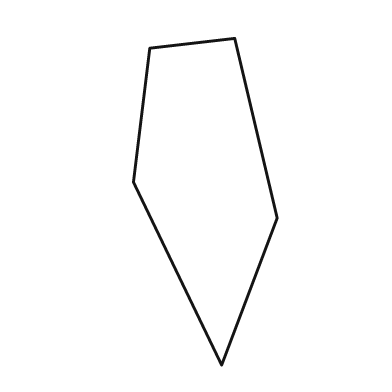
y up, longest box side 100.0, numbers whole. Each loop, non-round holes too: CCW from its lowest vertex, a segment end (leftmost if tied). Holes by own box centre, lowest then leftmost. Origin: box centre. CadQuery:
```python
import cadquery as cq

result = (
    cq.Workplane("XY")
    .moveTo(5.0, -50.0)
    .lineTo(22.0, -5.0)
    .lineTo(9.0, 50.0)
    .lineTo(-17.0, 47.0)
    .lineTo(-22.0, 6.0)
    .close()
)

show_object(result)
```